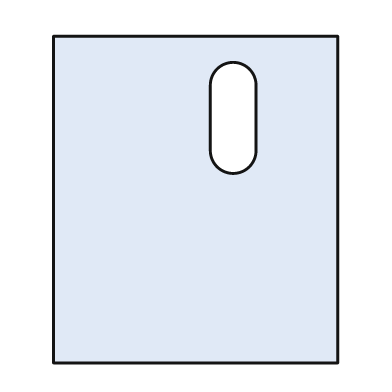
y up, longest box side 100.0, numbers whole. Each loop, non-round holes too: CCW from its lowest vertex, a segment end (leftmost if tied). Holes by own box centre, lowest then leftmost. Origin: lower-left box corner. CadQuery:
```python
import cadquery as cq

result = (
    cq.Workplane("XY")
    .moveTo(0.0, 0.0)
    .lineTo(87.0, 0.0)
    .lineTo(87.0, 100.0)
    .lineTo(0.0, 100.0)
    .close()
    .moveTo(48.0, 65.0)
    .threePointArc((55.0, 58.0), (62.0, 65.0))
    .lineTo(62.0, 85.0)
    .threePointArc((55.0, 92.0), (48.0, 85.0))
    .close()
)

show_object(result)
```